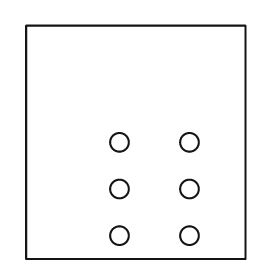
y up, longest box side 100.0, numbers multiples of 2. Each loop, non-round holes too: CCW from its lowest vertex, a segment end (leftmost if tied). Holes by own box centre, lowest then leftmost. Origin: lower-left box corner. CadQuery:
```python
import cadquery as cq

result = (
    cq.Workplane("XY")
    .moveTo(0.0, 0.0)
    .lineTo(94.0, 0.0)
    .lineTo(94.0, 100.0)
    .lineTo(0.0, 100.0)
    .close()
    .moveTo(40.0, 10.0)
    .circle(4.0)
    .moveTo(70.0, 10.0)
    .circle(4.0)
    .moveTo(40.0, 30.0)
    .circle(4.0)
    .moveTo(70.0, 30.0)
    .circle(4.0)
    .moveTo(40.0, 50.0)
    .circle(4.0)
    .moveTo(70.0, 50.0)
    .circle(4.0)
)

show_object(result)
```